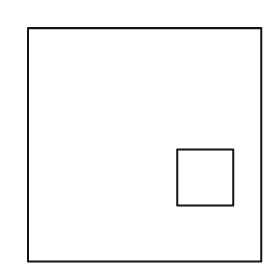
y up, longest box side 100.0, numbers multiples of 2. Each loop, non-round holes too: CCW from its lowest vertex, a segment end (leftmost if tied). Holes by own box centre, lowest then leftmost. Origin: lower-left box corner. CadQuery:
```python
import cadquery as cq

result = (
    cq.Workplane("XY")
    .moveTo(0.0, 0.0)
    .lineTo(100.0, 0.0)
    .lineTo(100.0, 100.0)
    .lineTo(0.0, 100.0)
    .close()
    .moveTo(64.0, 24.0)
    .lineTo(88.0, 24.0)
    .lineTo(88.0, 48.0)
    .lineTo(64.0, 48.0)
    .close()
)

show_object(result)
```